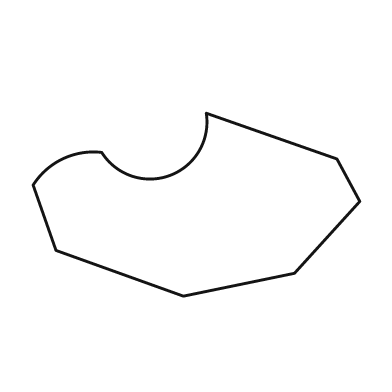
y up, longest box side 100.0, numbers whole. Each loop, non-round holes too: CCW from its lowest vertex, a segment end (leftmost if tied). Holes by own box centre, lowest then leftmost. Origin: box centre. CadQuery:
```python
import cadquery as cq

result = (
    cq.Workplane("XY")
    .moveTo(-4.0, -28.0)
    .lineTo(30.0, -21.0)
    .lineTo(50.0, 1.0)
    .lineTo(43.0, 14.0)
    .lineTo(3.0, 28.0)
    .threePointArc((-8.0, 9.0), (-29.0, 16.0))
    .threePointArc((-41.0, 14.0), (-50.0, 6.0))
    .lineTo(-43.0, -14.0)
    .close()
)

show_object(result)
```